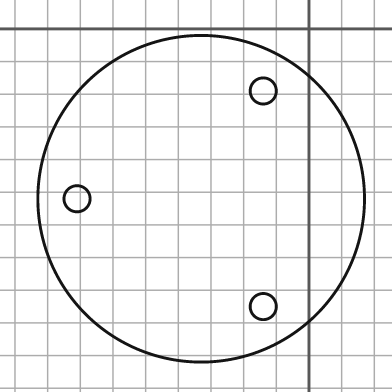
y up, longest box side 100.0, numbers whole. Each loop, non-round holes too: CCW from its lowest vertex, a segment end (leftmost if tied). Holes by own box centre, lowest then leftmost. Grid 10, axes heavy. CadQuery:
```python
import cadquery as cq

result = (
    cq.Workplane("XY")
    .moveTo(-33.0, -52.0)
    .circle(50.0)
    .moveTo(-14.0, -85.0)
    .circle(4.0)
    .moveTo(-71.0, -52.0)
    .circle(4.0)
    .moveTo(-14.0, -19.0)
    .circle(4.0)
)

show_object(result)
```